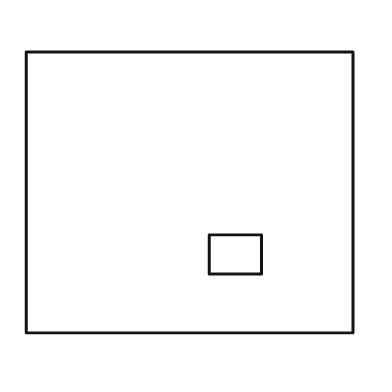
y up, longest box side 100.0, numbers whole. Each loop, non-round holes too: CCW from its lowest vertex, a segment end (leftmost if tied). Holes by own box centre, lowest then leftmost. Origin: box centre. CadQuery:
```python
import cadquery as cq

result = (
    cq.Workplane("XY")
    .moveTo(-50.0, -43.0)
    .lineTo(50.0, -43.0)
    .lineTo(50.0, 43.0)
    .lineTo(-50.0, 43.0)
    .close()
    .moveTo(6.0, -25.0)
    .lineTo(22.0, -25.0)
    .lineTo(22.0, -13.0)
    .lineTo(6.0, -13.0)
    .close()
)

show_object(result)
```